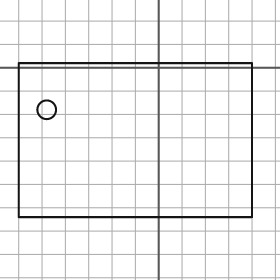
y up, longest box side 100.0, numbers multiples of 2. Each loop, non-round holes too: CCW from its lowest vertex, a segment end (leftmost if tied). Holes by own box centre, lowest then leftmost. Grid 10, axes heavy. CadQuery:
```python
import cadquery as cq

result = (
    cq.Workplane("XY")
    .moveTo(-60.0, -64.0)
    .lineTo(40.0, -64.0)
    .lineTo(40.0, 2.0)
    .lineTo(-60.0, 2.0)
    .close()
    .moveTo(-48.0, -18.0)
    .circle(4.0)
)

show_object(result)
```